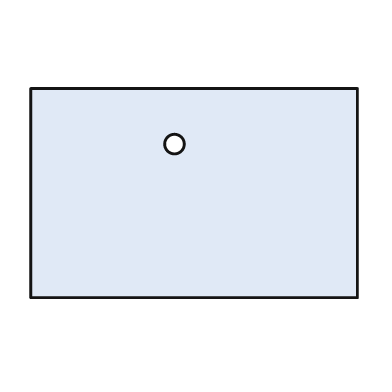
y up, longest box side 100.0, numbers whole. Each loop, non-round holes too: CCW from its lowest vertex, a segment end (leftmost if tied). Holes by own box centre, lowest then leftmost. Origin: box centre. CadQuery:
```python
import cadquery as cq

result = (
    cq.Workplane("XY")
    .moveTo(-50.0, -32.0)
    .lineTo(50.0, -32.0)
    .lineTo(50.0, 32.0)
    .lineTo(-50.0, 32.0)
    .close()
    .moveTo(-6.0, 15.0)
    .circle(3.0)
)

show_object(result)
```